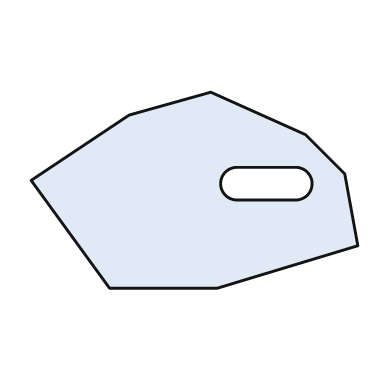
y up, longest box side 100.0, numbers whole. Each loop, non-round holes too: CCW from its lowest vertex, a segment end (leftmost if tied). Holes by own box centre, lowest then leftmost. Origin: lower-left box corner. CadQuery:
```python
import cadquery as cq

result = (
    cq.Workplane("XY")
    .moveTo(24.0, 0.0)
    .lineTo(57.0, 0.0)
    .lineTo(100.0, 13.0)
    .lineTo(96.0, 35.0)
    .lineTo(84.0, 47.0)
    .lineTo(55.0, 60.0)
    .lineTo(30.0, 53.0)
    .lineTo(0.0, 33.0)
    .close()
    .moveTo(63.0, 27.0)
    .lineTo(81.0, 27.0)
    .threePointArc((86.0, 32.0), (81.0, 37.0))
    .lineTo(63.0, 37.0)
    .threePointArc((58.0, 32.0), (63.0, 27.0))
    .close()
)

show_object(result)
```